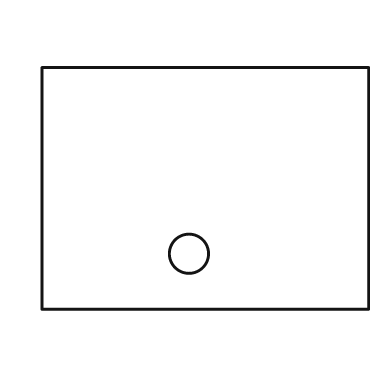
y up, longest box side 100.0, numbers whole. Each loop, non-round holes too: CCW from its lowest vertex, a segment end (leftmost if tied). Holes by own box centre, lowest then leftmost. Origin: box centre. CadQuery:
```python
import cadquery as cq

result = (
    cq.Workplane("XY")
    .moveTo(-50.0, -37.0)
    .lineTo(50.0, -37.0)
    .lineTo(50.0, 37.0)
    .lineTo(-50.0, 37.0)
    .close()
    .moveTo(-5.0, -20.0)
    .circle(6.0)
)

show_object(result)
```